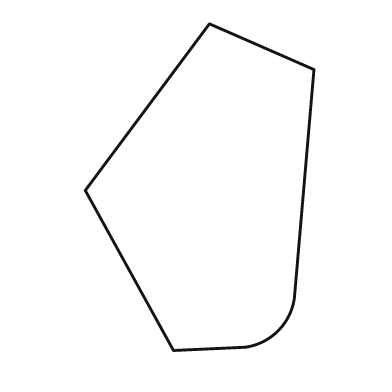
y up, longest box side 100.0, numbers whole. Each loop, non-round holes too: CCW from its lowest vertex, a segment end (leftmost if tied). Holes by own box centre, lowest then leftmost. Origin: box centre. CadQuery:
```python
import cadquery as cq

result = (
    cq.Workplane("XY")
    .moveTo(-8.0, -50.0)
    .lineTo(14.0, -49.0)
    .threePointArc((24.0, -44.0), (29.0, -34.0))
    .lineTo(35.0, 36.0)
    .lineTo(3.0, 50.0)
    .lineTo(-35.0, -1.0)
    .close()
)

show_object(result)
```